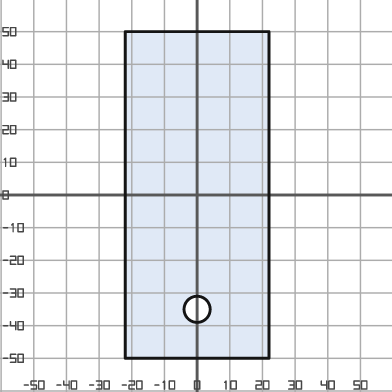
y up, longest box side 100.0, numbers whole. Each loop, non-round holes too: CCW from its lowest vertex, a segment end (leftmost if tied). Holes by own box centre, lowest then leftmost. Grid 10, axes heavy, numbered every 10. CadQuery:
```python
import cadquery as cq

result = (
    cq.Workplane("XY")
    .moveTo(-22.0, -50.0)
    .lineTo(22.0, -50.0)
    .lineTo(22.0, 50.0)
    .lineTo(-22.0, 50.0)
    .close()
    .moveTo(0.0, -35.0)
    .circle(4.0)
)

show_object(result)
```